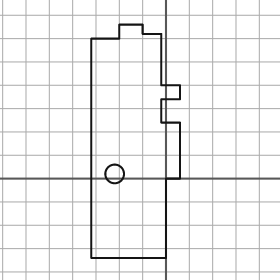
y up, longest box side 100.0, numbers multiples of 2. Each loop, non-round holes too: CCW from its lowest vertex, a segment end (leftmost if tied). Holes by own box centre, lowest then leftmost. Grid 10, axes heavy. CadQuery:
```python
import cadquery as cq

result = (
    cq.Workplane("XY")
    .moveTo(-32.0, -34.0)
    .lineTo(0.0, -34.0)
    .lineTo(0.0, 0.0)
    .lineTo(6.0, 0.0)
    .lineTo(6.0, 24.0)
    .lineTo(-2.0, 24.0)
    .lineTo(-2.0, 34.0)
    .lineTo(6.0, 34.0)
    .lineTo(6.0, 40.0)
    .lineTo(-2.0, 40.0)
    .lineTo(-2.0, 62.0)
    .lineTo(-10.0, 62.0)
    .lineTo(-10.0, 66.0)
    .lineTo(-20.0, 66.0)
    .lineTo(-20.0, 60.0)
    .lineTo(-32.0, 60.0)
    .close()
    .moveTo(-22.0, 2.0)
    .circle(4.0)
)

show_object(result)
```